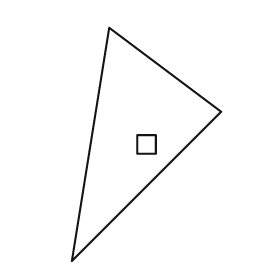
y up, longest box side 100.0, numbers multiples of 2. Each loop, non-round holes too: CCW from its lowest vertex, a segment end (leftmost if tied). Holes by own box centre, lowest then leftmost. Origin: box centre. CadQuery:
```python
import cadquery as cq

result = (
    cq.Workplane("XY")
    .moveTo(-32.0, -50.0)
    .lineTo(32.0, 14.0)
    .lineTo(-16.0, 50.0)
    .close()
    .moveTo(-4.0, -4.0)
    .lineTo(4.0, -4.0)
    .lineTo(4.0, 4.0)
    .lineTo(-4.0, 4.0)
    .close()
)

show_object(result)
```